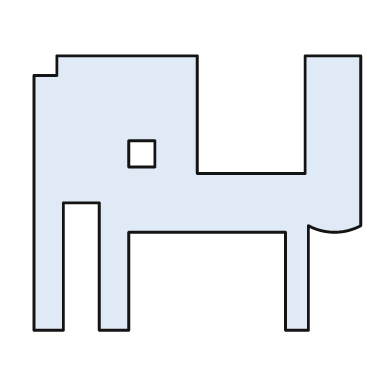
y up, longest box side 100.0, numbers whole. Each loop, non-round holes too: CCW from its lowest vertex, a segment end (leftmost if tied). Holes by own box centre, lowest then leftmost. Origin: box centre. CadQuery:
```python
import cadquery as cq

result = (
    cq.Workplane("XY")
    .moveTo(-50.0, -42.0)
    .lineTo(-41.0, -42.0)
    .lineTo(-41.0, -3.0)
    .lineTo(-30.0, -3.0)
    .lineTo(-30.0, -42.0)
    .lineTo(-21.0, -42.0)
    .lineTo(-21.0, -12.0)
    .lineTo(27.0, -12.0)
    .lineTo(27.0, -42.0)
    .lineTo(34.0, -42.0)
    .lineTo(34.0, -10.0)
    .threePointArc((42.0, -12.0), (50.0, -10.0))
    .lineTo(50.0, 42.0)
    .lineTo(33.0, 42.0)
    .lineTo(33.0, 6.0)
    .lineTo(0.0, 6.0)
    .lineTo(0.0, 42.0)
    .lineTo(-43.0, 42.0)
    .lineTo(-43.0, 36.0)
    .lineTo(-50.0, 36.0)
    .close()
    .moveTo(-21.0, 8.0)
    .lineTo(-13.0, 8.0)
    .lineTo(-13.0, 16.0)
    .lineTo(-21.0, 16.0)
    .close()
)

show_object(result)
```